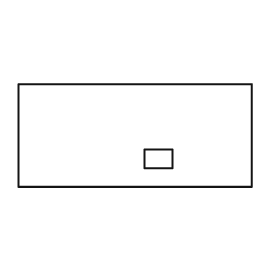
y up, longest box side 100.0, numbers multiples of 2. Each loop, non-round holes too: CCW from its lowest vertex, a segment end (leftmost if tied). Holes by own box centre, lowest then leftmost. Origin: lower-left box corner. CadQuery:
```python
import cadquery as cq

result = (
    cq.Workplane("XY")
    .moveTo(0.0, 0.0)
    .lineTo(100.0, 0.0)
    .lineTo(100.0, 44.0)
    .lineTo(0.0, 44.0)
    .close()
    .moveTo(54.0, 8.0)
    .lineTo(66.0, 8.0)
    .lineTo(66.0, 16.0)
    .lineTo(54.0, 16.0)
    .close()
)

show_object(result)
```